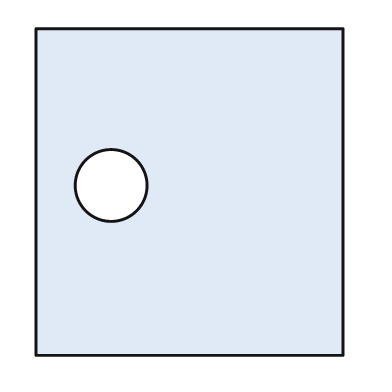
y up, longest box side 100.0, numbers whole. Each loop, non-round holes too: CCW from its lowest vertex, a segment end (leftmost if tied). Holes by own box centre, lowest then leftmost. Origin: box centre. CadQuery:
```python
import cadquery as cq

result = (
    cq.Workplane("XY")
    .moveTo(-47.0, -50.0)
    .lineTo(47.0, -50.0)
    .lineTo(47.0, 50.0)
    .lineTo(-47.0, 50.0)
    .close()
    .moveTo(-24.0, 2.0)
    .circle(11.0)
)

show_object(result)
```